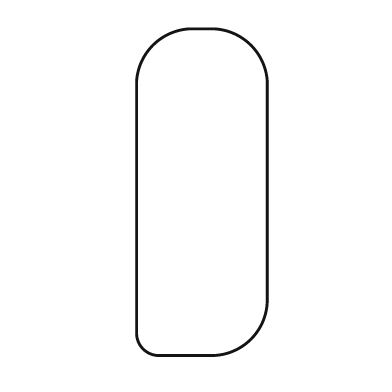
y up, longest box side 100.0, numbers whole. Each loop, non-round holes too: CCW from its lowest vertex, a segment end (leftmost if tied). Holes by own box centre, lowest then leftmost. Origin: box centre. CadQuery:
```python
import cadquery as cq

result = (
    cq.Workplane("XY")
    .moveTo(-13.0, -50.0)
    .lineTo(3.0, -50.0)
    .threePointArc((15.0, -45.0), (20.0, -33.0))
    .lineTo(20.0, 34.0)
    .threePointArc((15.0, 45.0), (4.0, 50.0))
    .lineTo(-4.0, 50.0)
    .threePointArc((-15.0, 45.0), (-20.0, 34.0))
    .lineTo(-20.0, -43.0)
    .threePointArc((-18.0, -48.0), (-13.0, -50.0))
    .close()
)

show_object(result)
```